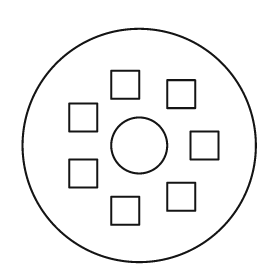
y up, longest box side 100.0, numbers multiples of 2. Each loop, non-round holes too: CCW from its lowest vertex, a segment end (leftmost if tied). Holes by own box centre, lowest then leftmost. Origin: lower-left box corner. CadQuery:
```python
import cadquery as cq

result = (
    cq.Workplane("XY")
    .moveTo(50.0, 50.0)
    .circle(50.0)
    .moveTo(38.0, 16.0)
    .lineTo(50.0, 16.0)
    .lineTo(50.0, 28.0)
    .lineTo(38.0, 28.0)
    .close()
    .moveTo(62.0, 22.0)
    .lineTo(74.0, 22.0)
    .lineTo(74.0, 34.0)
    .lineTo(62.0, 34.0)
    .close()
    .moveTo(20.0, 32.0)
    .lineTo(32.0, 32.0)
    .lineTo(32.0, 44.0)
    .lineTo(20.0, 44.0)
    .close()
    .moveTo(50.0, 50.0)
    .circle(12.0)
    .moveTo(72.0, 44.0)
    .lineTo(84.0, 44.0)
    .lineTo(84.0, 56.0)
    .lineTo(72.0, 56.0)
    .close()
    .moveTo(20.0, 56.0)
    .lineTo(32.0, 56.0)
    .lineTo(32.0, 68.0)
    .lineTo(20.0, 68.0)
    .close()
    .moveTo(62.0, 66.0)
    .lineTo(74.0, 66.0)
    .lineTo(74.0, 78.0)
    .lineTo(62.0, 78.0)
    .close()
    .moveTo(38.0, 70.0)
    .lineTo(50.0, 70.0)
    .lineTo(50.0, 82.0)
    .lineTo(38.0, 82.0)
    .close()
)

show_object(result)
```